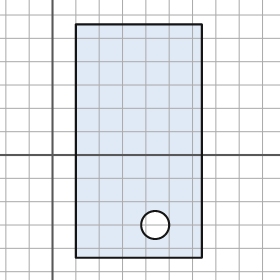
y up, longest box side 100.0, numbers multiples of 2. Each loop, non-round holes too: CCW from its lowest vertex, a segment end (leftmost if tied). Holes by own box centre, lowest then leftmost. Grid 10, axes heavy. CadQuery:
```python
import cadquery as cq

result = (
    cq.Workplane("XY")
    .moveTo(10.0, -44.0)
    .lineTo(64.0, -44.0)
    .lineTo(64.0, 56.0)
    .lineTo(10.0, 56.0)
    .close()
    .moveTo(44.0, -30.0)
    .circle(6.0)
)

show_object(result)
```